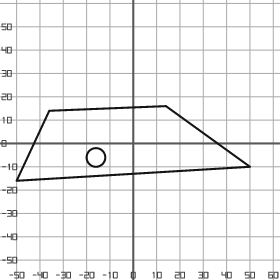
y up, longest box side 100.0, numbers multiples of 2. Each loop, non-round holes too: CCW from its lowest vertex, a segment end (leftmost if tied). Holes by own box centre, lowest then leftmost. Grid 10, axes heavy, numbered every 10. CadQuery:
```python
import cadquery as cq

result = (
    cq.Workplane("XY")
    .moveTo(-50.0, -16.0)
    .lineTo(50.0, -10.0)
    .lineTo(14.0, 16.0)
    .lineTo(-36.0, 14.0)
    .close()
    .moveTo(-16.0, -6.0)
    .circle(4.0)
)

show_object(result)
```